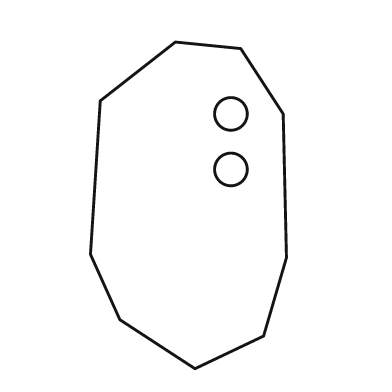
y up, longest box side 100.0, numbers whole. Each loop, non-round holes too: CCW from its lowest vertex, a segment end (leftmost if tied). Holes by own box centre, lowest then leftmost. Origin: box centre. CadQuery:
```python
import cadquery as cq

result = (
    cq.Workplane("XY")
    .moveTo(2.0, -50.0)
    .lineTo(23.0, -40.0)
    .lineTo(30.0, -16.0)
    .lineTo(29.0, 28.0)
    .lineTo(16.0, 48.0)
    .lineTo(-4.0, 50.0)
    .lineTo(-27.0, 32.0)
    .lineTo(-30.0, -15.0)
    .lineTo(-21.0, -35.0)
    .close()
    .moveTo(13.0, 11.0)
    .circle(5.0)
    .moveTo(13.0, 28.0)
    .circle(5.0)
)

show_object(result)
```